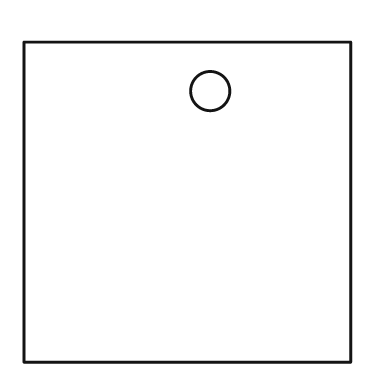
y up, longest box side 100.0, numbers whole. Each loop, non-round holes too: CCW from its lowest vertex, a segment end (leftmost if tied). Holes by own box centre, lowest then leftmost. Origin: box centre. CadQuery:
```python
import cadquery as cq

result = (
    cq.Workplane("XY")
    .moveTo(-50.0, -49.0)
    .lineTo(50.0, -49.0)
    .lineTo(50.0, 49.0)
    .lineTo(-50.0, 49.0)
    .close()
    .moveTo(7.0, 34.0)
    .circle(6.0)
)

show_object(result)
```